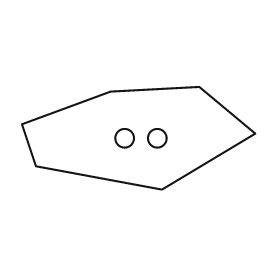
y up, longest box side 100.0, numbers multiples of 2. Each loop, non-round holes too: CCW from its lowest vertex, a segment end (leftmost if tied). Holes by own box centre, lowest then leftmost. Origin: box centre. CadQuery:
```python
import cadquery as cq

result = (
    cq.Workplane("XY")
    .moveTo(10.0, -22.0)
    .lineTo(50.0, 2.0)
    .lineTo(26.0, 22.0)
    .lineTo(-12.0, 20.0)
    .lineTo(-50.0, 6.0)
    .lineTo(-44.0, -12.0)
    .close()
    .moveTo(-6.0, 0.0)
    .circle(4.0)
    .moveTo(8.0, 0.0)
    .circle(4.0)
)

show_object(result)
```